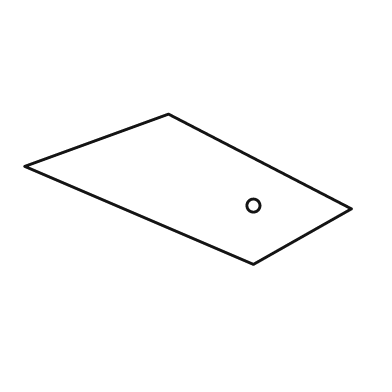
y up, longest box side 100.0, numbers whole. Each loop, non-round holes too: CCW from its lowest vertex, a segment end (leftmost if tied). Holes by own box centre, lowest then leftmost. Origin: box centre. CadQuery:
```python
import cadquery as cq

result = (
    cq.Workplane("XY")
    .moveTo(20.0, -23.0)
    .lineTo(50.0, -6.0)
    .lineTo(-6.0, 23.0)
    .lineTo(-50.0, 7.0)
    .close()
    .moveTo(20.0, -5.0)
    .circle(2.0)
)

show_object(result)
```